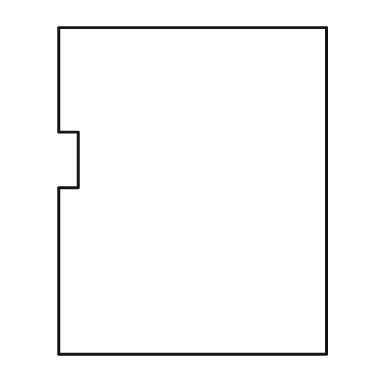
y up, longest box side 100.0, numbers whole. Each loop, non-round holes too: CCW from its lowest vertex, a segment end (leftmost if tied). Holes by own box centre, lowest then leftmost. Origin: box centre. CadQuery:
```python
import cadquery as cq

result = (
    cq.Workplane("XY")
    .moveTo(-41.0, -50.0)
    .lineTo(41.0, -50.0)
    .lineTo(41.0, 50.0)
    .lineTo(-41.0, 50.0)
    .lineTo(-41.0, 18.0)
    .lineTo(-35.0, 18.0)
    .lineTo(-35.0, 1.0)
    .lineTo(-41.0, 1.0)
    .close()
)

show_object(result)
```